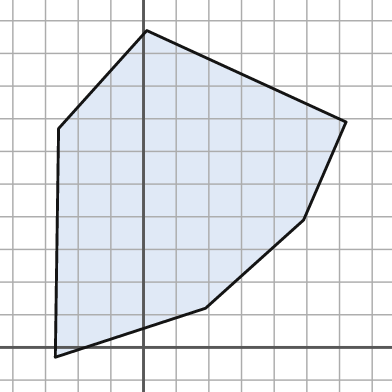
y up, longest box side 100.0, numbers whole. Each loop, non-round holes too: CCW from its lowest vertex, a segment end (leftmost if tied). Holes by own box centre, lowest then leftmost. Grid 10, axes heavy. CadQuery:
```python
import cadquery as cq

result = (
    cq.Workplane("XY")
    .moveTo(-27.0, -3.0)
    .lineTo(19.0, 12.0)
    .lineTo(49.0, 39.0)
    .lineTo(62.0, 69.0)
    .lineTo(1.0, 97.0)
    .lineTo(-26.0, 67.0)
    .close()
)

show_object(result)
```